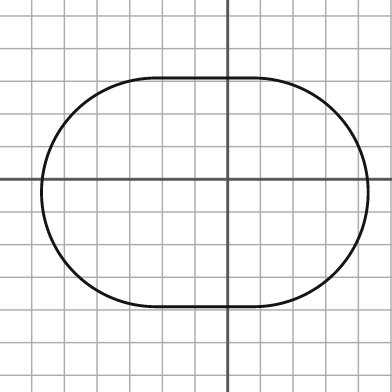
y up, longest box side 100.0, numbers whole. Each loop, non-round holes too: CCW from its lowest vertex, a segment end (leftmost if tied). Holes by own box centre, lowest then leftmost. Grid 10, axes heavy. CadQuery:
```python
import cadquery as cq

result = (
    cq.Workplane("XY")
    .moveTo(-22.0, -39.0)
    .lineTo(8.0, -39.0)
    .threePointArc((43.0, -4.0), (8.0, 31.0))
    .lineTo(-22.0, 31.0)
    .threePointArc((-57.0, -4.0), (-22.0, -39.0))
    .close()
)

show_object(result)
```